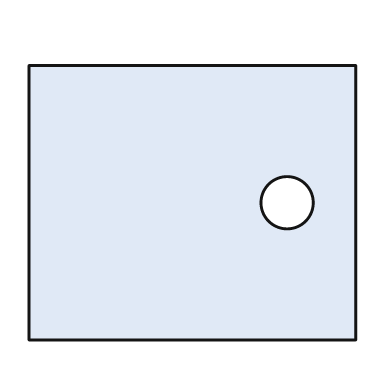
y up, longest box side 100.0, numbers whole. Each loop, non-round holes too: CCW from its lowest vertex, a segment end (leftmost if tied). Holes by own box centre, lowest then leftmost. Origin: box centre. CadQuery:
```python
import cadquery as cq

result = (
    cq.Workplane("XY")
    .moveTo(-50.0, -42.0)
    .lineTo(50.0, -42.0)
    .lineTo(50.0, 42.0)
    .lineTo(-50.0, 42.0)
    .close()
    .moveTo(29.0, 0.0)
    .circle(8.0)
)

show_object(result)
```